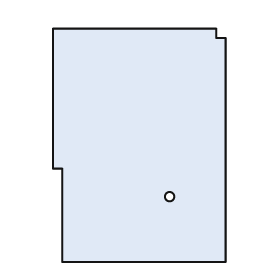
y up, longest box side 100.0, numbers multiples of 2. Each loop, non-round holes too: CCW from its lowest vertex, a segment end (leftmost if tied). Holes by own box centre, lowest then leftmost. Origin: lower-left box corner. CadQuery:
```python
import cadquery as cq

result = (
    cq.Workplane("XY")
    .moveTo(4.0, 0.0)
    .lineTo(74.0, 0.0)
    .lineTo(74.0, 96.0)
    .lineTo(70.0, 96.0)
    .lineTo(70.0, 100.0)
    .lineTo(0.0, 100.0)
    .lineTo(0.0, 40.0)
    .lineTo(4.0, 40.0)
    .close()
    .moveTo(50.0, 28.0)
    .circle(2.0)
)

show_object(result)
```